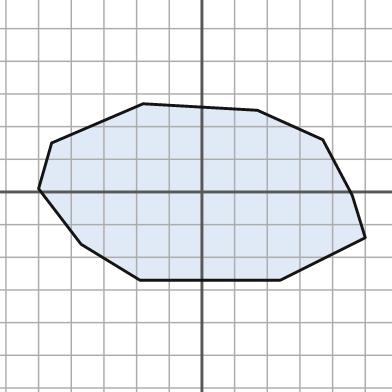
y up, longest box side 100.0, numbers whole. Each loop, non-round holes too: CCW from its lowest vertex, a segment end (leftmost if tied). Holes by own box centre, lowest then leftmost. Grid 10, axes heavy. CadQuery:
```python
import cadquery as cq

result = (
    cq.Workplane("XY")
    .moveTo(-19.0, -27.0)
    .lineTo(24.0, -27.0)
    .lineTo(50.0, -14.0)
    .lineTo(46.0, -1.0)
    .lineTo(37.0, 16.0)
    .lineTo(17.0, 25.0)
    .lineTo(-18.0, 27.0)
    .lineTo(-46.0, 15.0)
    .lineTo(-50.0, 1.0)
    .lineTo(-37.0, -16.0)
    .close()
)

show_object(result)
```